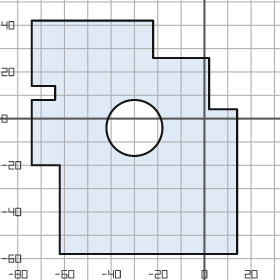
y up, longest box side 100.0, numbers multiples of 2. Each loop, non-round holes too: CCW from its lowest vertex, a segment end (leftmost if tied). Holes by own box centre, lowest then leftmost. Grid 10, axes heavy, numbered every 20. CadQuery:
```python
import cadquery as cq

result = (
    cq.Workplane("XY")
    .moveTo(-62.0, -58.0)
    .lineTo(14.0, -58.0)
    .lineTo(14.0, 4.0)
    .lineTo(2.0, 4.0)
    .lineTo(2.0, 26.0)
    .lineTo(-22.0, 26.0)
    .lineTo(-22.0, 42.0)
    .lineTo(-74.0, 42.0)
    .lineTo(-74.0, 14.0)
    .lineTo(-64.0, 14.0)
    .lineTo(-64.0, 8.0)
    .lineTo(-74.0, 8.0)
    .lineTo(-74.0, -20.0)
    .lineTo(-62.0, -20.0)
    .close()
    .moveTo(-30.0, -4.0)
    .circle(12.0)
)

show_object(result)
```